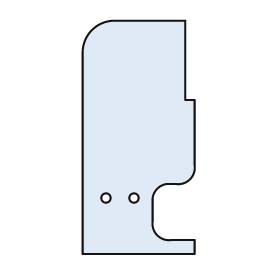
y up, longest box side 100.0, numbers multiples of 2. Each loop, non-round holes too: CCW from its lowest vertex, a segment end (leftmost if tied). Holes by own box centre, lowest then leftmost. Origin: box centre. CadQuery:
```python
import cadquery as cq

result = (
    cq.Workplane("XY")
    .moveTo(-24.0, -50.0)
    .lineTo(24.0, -50.0)
    .lineTo(24.0, -44.0)
    .lineTo(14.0, -44.0)
    .threePointArc((8.0, -42.0), (6.0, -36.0))
    .lineTo(6.0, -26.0)
    .threePointArc((8.0, -22.0), (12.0, -20.0))
    .lineTo(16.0, -20.0)
    .threePointArc((22.0, -18.0), (24.0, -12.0))
    .lineTo(24.0, 16.0)
    .lineTo(20.0, 16.0)
    .lineTo(20.0, 50.0)
    .lineTo(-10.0, 50.0)
    .threePointArc((-20.0, 46.0), (-24.0, 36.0))
    .close()
    .moveTo(-14.0, -26.0)
    .circle(2.0)
    .moveTo(-2.0, -26.0)
    .circle(2.0)
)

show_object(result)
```